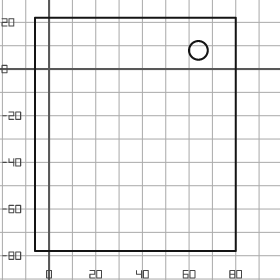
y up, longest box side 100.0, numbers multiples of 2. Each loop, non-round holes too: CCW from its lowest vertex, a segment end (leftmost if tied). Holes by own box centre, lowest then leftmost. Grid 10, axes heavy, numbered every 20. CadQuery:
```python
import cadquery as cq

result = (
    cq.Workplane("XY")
    .moveTo(-6.0, -78.0)
    .lineTo(80.0, -78.0)
    .lineTo(80.0, 22.0)
    .lineTo(-6.0, 22.0)
    .close()
    .moveTo(64.0, 8.0)
    .circle(4.0)
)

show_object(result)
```